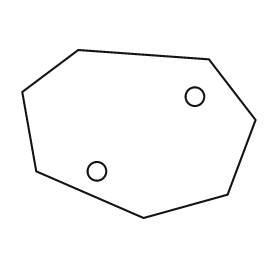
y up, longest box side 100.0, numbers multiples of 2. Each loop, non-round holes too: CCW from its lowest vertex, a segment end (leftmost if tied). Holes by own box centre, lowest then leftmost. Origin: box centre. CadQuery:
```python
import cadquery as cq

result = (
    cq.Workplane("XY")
    .moveTo(2.0, -36.0)
    .lineTo(38.0, -26.0)
    .lineTo(50.0, 6.0)
    .lineTo(30.0, 32.0)
    .lineTo(-26.0, 36.0)
    .lineTo(-50.0, 18.0)
    .lineTo(-44.0, -16.0)
    .close()
    .moveTo(-18.0, -16.0)
    .circle(4.0)
    .moveTo(24.0, 16.0)
    .circle(4.0)
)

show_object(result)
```